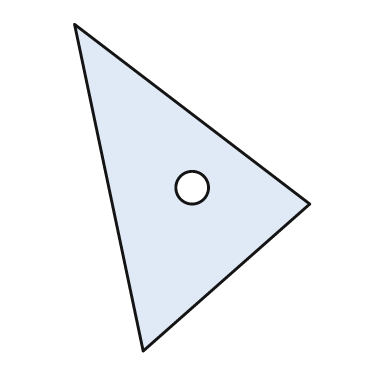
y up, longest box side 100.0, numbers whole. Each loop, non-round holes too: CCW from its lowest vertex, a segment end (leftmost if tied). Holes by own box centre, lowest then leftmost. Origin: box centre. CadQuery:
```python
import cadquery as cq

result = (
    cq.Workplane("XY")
    .moveTo(-15.0, -50.0)
    .lineTo(36.0, -5.0)
    .lineTo(-36.0, 50.0)
    .close()
    .moveTo(0.0, 0.0)
    .circle(5.0)
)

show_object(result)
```